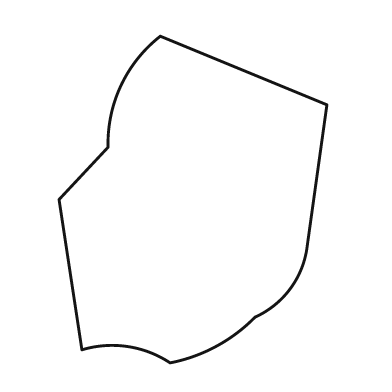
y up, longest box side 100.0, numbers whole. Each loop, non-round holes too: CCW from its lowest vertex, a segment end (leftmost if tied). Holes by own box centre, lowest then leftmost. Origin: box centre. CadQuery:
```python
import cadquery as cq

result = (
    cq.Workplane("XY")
    .moveTo(-7.0, -50.0)
    .threePointArc((7.0, -45.0), (19.0, -36.0))
    .threePointArc((30.0, -27.0), (35.0, -14.0))
    .lineTo(41.0, 29.0)
    .lineTo(-10.0, 50.0)
    .threePointArc((-22.0, 35.0), (-26.0, 16.0))
    .lineTo(-41.0, 0.0)
    .lineTo(-34.0, -46.0)
    .threePointArc((-20.0, -45.0), (-7.0, -50.0))
    .close()
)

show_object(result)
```